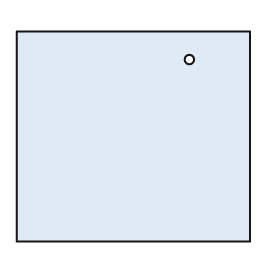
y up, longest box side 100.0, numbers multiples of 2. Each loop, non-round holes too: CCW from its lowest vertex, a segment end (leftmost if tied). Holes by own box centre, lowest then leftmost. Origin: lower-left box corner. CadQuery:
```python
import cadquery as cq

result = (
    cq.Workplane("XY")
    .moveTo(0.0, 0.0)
    .lineTo(100.0, 0.0)
    .lineTo(100.0, 90.0)
    .lineTo(0.0, 90.0)
    .close()
    .moveTo(74.0, 78.0)
    .circle(2.0)
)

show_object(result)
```